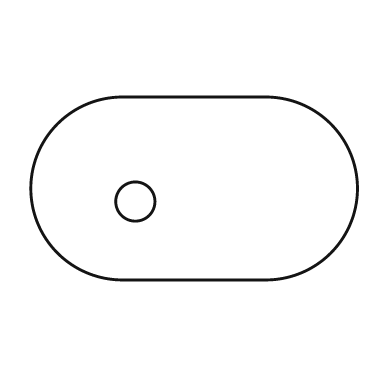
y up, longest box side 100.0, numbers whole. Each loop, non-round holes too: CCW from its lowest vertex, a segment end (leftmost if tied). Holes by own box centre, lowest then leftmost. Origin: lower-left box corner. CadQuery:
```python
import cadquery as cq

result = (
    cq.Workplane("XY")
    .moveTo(28.0, 0.0)
    .lineTo(72.0, 0.0)
    .threePointArc((100.0, 28.0), (72.0, 56.0))
    .lineTo(28.0, 56.0)
    .threePointArc((0.0, 28.0), (28.0, 0.0))
    .close()
    .moveTo(32.0, 24.0)
    .circle(6.0)
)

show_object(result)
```